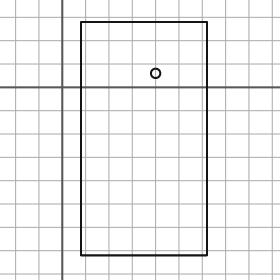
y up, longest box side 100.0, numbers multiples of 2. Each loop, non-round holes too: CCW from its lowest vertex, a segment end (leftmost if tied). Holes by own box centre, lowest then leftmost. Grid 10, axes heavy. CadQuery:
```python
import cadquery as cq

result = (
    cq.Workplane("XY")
    .moveTo(8.0, -72.0)
    .lineTo(62.0, -72.0)
    .lineTo(62.0, 28.0)
    .lineTo(8.0, 28.0)
    .close()
    .moveTo(40.0, 6.0)
    .circle(2.0)
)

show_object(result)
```